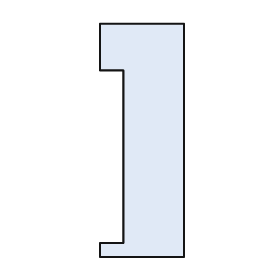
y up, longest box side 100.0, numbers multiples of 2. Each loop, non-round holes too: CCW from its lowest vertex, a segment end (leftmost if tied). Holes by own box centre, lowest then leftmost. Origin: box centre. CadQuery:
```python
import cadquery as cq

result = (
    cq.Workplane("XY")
    .moveTo(-18.0, -50.0)
    .lineTo(18.0, -50.0)
    .lineTo(18.0, 50.0)
    .lineTo(-18.0, 50.0)
    .lineTo(-18.0, 30.0)
    .lineTo(-8.0, 30.0)
    .lineTo(-8.0, -44.0)
    .lineTo(-18.0, -44.0)
    .close()
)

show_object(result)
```